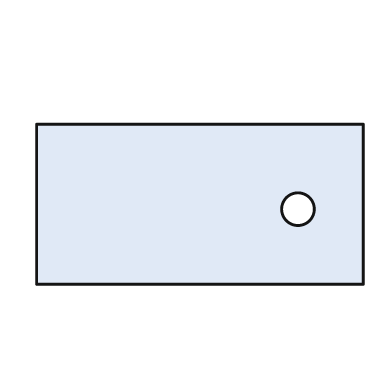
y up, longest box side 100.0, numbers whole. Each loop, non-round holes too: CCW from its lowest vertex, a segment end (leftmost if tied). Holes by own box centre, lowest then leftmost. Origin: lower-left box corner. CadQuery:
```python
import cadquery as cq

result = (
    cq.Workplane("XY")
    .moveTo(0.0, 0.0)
    .lineTo(100.0, 0.0)
    .lineTo(100.0, 49.0)
    .lineTo(0.0, 49.0)
    .close()
    .moveTo(80.0, 23.0)
    .circle(5.0)
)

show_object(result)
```